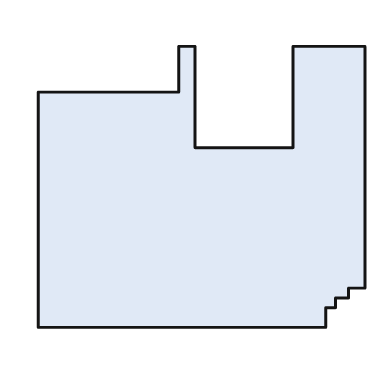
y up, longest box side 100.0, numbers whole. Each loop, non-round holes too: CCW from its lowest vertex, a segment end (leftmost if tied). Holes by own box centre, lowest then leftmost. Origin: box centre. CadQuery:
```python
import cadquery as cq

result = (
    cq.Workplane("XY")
    .moveTo(-50.0, -43.0)
    .lineTo(38.0, -43.0)
    .lineTo(38.0, -37.0)
    .lineTo(41.0, -37.0)
    .lineTo(41.0, -34.0)
    .lineTo(45.0, -34.0)
    .lineTo(45.0, -31.0)
    .lineTo(50.0, -31.0)
    .lineTo(50.0, 43.0)
    .lineTo(28.0, 43.0)
    .lineTo(28.0, 12.0)
    .lineTo(-2.0, 12.0)
    .lineTo(-2.0, 43.0)
    .lineTo(-7.0, 43.0)
    .lineTo(-7.0, 29.0)
    .lineTo(-50.0, 29.0)
    .close()
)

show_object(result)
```